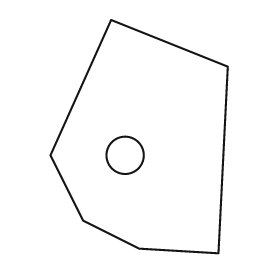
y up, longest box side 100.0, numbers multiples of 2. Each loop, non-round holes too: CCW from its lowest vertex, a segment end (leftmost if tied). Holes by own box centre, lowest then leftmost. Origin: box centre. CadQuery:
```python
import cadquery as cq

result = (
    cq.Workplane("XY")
    .moveTo(34.0, -50.0)
    .lineTo(38.0, 30.0)
    .lineTo(-12.0, 50.0)
    .lineTo(-38.0, -8.0)
    .lineTo(-24.0, -36.0)
    .lineTo(0.0, -48.0)
    .close()
    .moveTo(-6.0, -8.0)
    .circle(8.0)
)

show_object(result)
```